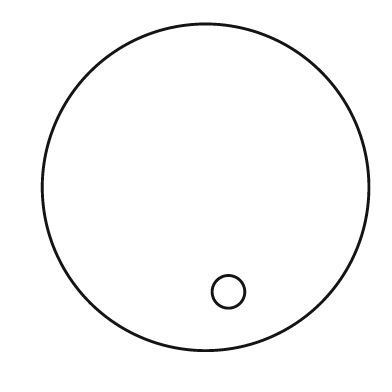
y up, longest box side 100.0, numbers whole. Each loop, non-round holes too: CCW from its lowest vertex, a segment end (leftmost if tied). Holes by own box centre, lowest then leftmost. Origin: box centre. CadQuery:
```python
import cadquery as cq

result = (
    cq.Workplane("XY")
    .moveTo(0.0, 0.0)
    .circle(50.0)
    .moveTo(7.0, -32.0)
    .circle(5.0)
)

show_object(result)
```